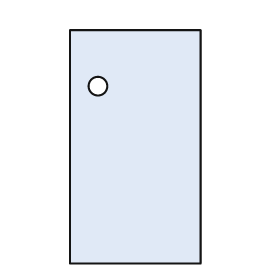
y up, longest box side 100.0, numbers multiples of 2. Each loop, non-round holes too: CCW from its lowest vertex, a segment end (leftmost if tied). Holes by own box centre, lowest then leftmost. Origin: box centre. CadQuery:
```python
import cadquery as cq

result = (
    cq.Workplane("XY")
    .moveTo(-28.0, -50.0)
    .lineTo(28.0, -50.0)
    .lineTo(28.0, 50.0)
    .lineTo(-28.0, 50.0)
    .close()
    .moveTo(-16.0, 26.0)
    .circle(4.0)
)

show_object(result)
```